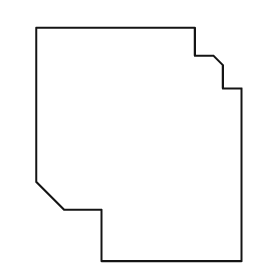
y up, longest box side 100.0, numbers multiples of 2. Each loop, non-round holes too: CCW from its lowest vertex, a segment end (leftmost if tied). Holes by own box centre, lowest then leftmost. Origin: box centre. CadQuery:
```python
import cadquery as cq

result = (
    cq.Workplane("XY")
    .moveTo(-16.0, -50.0)
    .lineTo(44.0, -50.0)
    .lineTo(44.0, 24.0)
    .lineTo(36.0, 24.0)
    .lineTo(36.0, 34.0)
    .lineTo(32.0, 38.0)
    .lineTo(24.0, 38.0)
    .lineTo(24.0, 50.0)
    .lineTo(-44.0, 50.0)
    .lineTo(-44.0, -16.0)
    .lineTo(-32.0, -28.0)
    .lineTo(-16.0, -28.0)
    .close()
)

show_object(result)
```